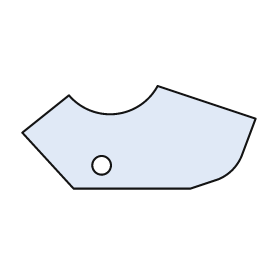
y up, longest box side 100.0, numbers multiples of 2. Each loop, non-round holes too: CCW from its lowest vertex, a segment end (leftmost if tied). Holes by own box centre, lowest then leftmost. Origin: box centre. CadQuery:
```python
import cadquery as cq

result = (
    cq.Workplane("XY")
    .moveTo(-28.0, -22.0)
    .lineTo(22.0, -22.0)
    .lineTo(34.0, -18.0)
    .threePointArc((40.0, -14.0), (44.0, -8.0))
    .lineTo(50.0, 8.0)
    .lineTo(8.0, 22.0)
    .threePointArc((-10.0, 10.0), (-30.0, 18.0))
    .lineTo(-50.0, 2.0)
    .close()
    .moveTo(-16.0, -12.0)
    .circle(4.0)
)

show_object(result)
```